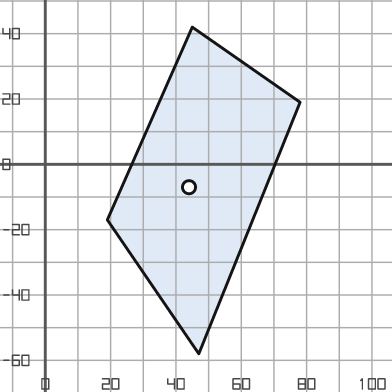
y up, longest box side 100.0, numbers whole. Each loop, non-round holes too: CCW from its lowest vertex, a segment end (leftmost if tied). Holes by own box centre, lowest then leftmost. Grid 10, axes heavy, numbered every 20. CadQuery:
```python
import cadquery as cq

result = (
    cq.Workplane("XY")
    .moveTo(47.0, -58.0)
    .lineTo(78.0, 19.0)
    .lineTo(45.0, 42.0)
    .lineTo(19.0, -17.0)
    .close()
    .moveTo(44.0, -7.0)
    .circle(2.0)
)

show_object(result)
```